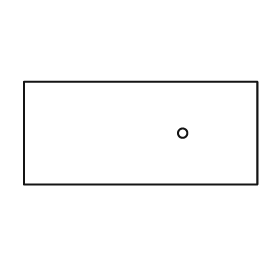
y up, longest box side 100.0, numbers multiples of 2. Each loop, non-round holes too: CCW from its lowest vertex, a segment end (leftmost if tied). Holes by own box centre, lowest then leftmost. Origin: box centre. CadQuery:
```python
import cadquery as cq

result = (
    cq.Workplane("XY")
    .moveTo(-50.0, -22.0)
    .lineTo(50.0, -22.0)
    .lineTo(50.0, 22.0)
    .lineTo(-50.0, 22.0)
    .close()
    .moveTo(18.0, 0.0)
    .circle(2.0)
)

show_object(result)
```